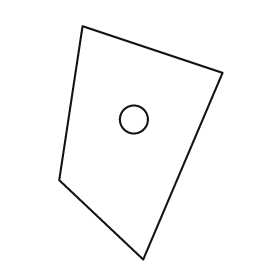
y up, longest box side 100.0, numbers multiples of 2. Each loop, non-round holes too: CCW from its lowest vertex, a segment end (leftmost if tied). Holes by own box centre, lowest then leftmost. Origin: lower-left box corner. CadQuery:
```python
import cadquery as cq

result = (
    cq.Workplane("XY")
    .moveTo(36.0, 0.0)
    .lineTo(70.0, 80.0)
    .lineTo(10.0, 100.0)
    .lineTo(0.0, 34.0)
    .close()
    .moveTo(32.0, 60.0)
    .circle(6.0)
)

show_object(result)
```